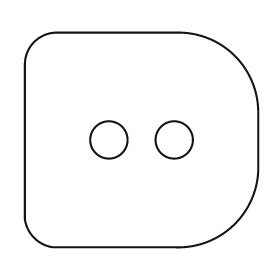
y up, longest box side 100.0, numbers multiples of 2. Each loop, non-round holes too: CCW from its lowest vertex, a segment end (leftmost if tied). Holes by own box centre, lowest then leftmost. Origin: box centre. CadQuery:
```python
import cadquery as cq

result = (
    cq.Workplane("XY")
    .moveTo(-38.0, -46.0)
    .lineTo(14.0, -46.0)
    .threePointArc((40.0, -36.0), (50.0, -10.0))
    .lineTo(50.0, 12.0)
    .threePointArc((40.0, 36.0), (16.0, 46.0))
    .lineTo(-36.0, 46.0)
    .threePointArc((-46.0, 42.0), (-50.0, 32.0))
    .lineTo(-50.0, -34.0)
    .threePointArc((-46.0, -42.0), (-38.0, -46.0))
    .close()
    .moveTo(-14.0, 0.0)
    .circle(8.0)
    .moveTo(14.0, 0.0)
    .circle(8.0)
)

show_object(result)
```